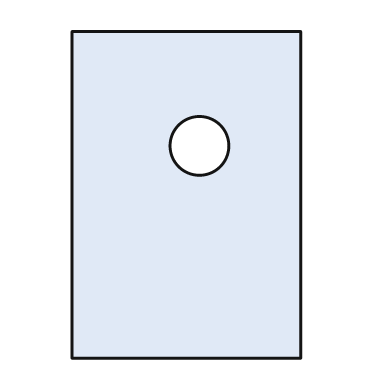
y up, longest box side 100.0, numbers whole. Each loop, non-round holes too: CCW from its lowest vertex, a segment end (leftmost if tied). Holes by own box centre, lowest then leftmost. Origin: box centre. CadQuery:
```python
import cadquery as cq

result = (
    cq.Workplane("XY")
    .moveTo(-35.0, -50.0)
    .lineTo(35.0, -50.0)
    .lineTo(35.0, 50.0)
    .lineTo(-35.0, 50.0)
    .close()
    .moveTo(4.0, 15.0)
    .circle(9.0)
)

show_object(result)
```